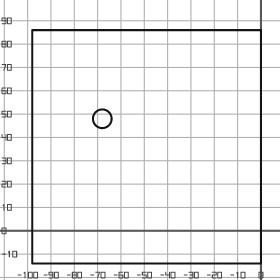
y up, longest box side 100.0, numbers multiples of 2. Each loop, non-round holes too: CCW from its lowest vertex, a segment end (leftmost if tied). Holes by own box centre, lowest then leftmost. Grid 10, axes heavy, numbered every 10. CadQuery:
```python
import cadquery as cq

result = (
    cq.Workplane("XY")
    .moveTo(-98.0, -14.0)
    .lineTo(0.0, -14.0)
    .lineTo(0.0, 86.0)
    .lineTo(-98.0, 86.0)
    .close()
    .moveTo(-68.0, 48.0)
    .circle(4.0)
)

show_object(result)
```